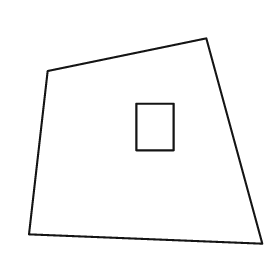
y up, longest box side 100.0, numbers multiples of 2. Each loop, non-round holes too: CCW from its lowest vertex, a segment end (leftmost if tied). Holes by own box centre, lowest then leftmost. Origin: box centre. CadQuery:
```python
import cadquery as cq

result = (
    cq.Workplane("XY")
    .moveTo(50.0, -44.0)
    .lineTo(26.0, 44.0)
    .lineTo(-42.0, 30.0)
    .lineTo(-50.0, -40.0)
    .close()
    .moveTo(-4.0, -4.0)
    .lineTo(12.0, -4.0)
    .lineTo(12.0, 16.0)
    .lineTo(-4.0, 16.0)
    .close()
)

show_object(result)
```